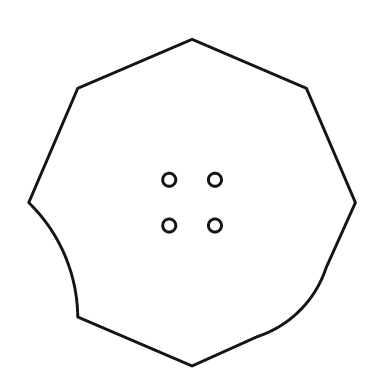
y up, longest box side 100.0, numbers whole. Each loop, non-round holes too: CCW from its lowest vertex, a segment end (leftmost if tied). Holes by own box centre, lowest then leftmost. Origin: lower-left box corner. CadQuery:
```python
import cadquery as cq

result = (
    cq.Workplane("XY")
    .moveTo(50.0, 0.0)
    .lineTo(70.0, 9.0)
    .threePointArc((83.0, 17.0), (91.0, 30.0))
    .lineTo(100.0, 50.0)
    .lineTo(85.0, 85.0)
    .lineTo(50.0, 100.0)
    .lineTo(15.0, 85.0)
    .lineTo(0.0, 50.0)
    .threePointArc((11.0, 34.0), (15.0, 15.0))
    .close()
    .moveTo(43.0, 43.0)
    .circle(2.0)
    .moveTo(57.0, 43.0)
    .circle(2.0)
    .moveTo(43.0, 57.0)
    .circle(2.0)
    .moveTo(57.0, 57.0)
    .circle(2.0)
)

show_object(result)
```